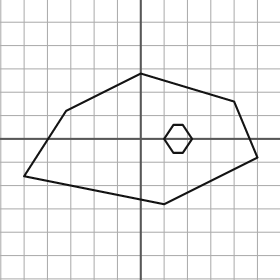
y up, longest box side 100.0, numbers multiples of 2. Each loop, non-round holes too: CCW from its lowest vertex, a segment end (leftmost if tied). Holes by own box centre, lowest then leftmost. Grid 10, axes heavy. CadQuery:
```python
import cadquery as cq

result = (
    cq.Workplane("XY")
    .moveTo(10.0, -28.0)
    .lineTo(50.0, -8.0)
    .lineTo(40.0, 16.0)
    .lineTo(0.0, 28.0)
    .lineTo(-32.0, 12.0)
    .lineTo(-50.0, -16.0)
    .close()
    .moveTo(14.0, -6.0)
    .lineTo(18.0, -6.0)
    .lineTo(22.0, 0.0)
    .lineTo(18.0, 6.0)
    .lineTo(14.0, 6.0)
    .lineTo(10.0, 0.0)
    .close()
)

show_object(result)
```